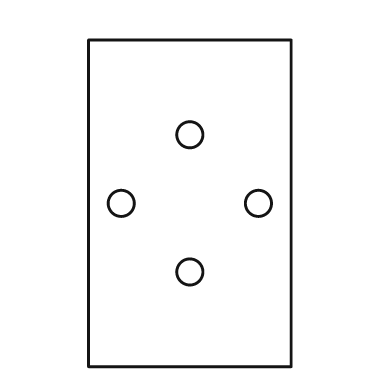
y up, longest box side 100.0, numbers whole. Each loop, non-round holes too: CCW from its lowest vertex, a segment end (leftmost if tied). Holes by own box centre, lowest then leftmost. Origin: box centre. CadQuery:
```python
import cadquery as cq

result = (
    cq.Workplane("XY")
    .moveTo(-31.0, -50.0)
    .lineTo(31.0, -50.0)
    .lineTo(31.0, 50.0)
    .lineTo(-31.0, 50.0)
    .close()
    .moveTo(0.0, -21.0)
    .circle(4.0)
    .moveTo(-21.0, 0.0)
    .circle(4.0)
    .moveTo(21.0, 0.0)
    .circle(4.0)
    .moveTo(0.0, 21.0)
    .circle(4.0)
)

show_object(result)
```